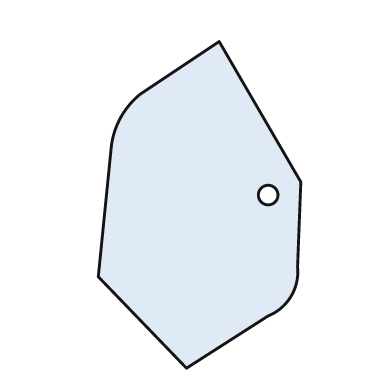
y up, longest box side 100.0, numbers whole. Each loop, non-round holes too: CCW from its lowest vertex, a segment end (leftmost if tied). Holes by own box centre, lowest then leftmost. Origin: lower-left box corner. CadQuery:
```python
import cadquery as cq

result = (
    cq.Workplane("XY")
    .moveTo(27.0, 0.0)
    .lineTo(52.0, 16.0)
    .threePointArc((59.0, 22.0), (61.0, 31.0))
    .lineTo(62.0, 57.0)
    .lineTo(37.0, 100.0)
    .lineTo(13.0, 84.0)
    .threePointArc((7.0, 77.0), (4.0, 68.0))
    .lineTo(0.0, 28.0)
    .close()
    .moveTo(52.0, 53.0)
    .circle(3.0)
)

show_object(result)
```